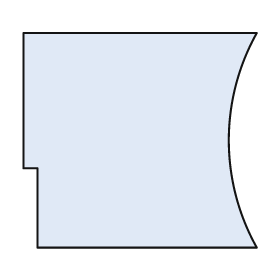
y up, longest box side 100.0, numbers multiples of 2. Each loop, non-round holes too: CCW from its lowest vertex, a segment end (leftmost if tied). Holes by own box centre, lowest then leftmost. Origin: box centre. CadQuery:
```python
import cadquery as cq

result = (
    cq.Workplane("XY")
    .moveTo(-44.0, -46.0)
    .lineTo(50.0, -46.0)
    .threePointArc((38.0, 0.0), (50.0, 46.0))
    .lineTo(-50.0, 46.0)
    .lineTo(-50.0, -12.0)
    .lineTo(-44.0, -12.0)
    .close()
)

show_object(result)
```